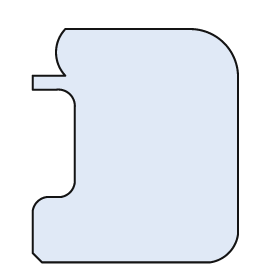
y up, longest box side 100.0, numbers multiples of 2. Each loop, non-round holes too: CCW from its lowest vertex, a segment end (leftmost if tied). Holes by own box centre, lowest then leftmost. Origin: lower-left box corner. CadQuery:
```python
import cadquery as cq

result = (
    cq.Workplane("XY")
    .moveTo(4.0, 0.0)
    .lineTo(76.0, 0.0)
    .threePointArc((84.0, 4.0), (88.0, 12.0))
    .lineTo(88.0, 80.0)
    .threePointArc((82.0, 94.0), (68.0, 100.0))
    .lineTo(14.0, 100.0)
    .threePointArc((10.0, 90.0), (14.0, 80.0))
    .lineTo(0.0, 80.0)
    .lineTo(0.0, 74.0)
    .lineTo(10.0, 74.0)
    .threePointArc((16.0, 72.0), (18.0, 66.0))
    .lineTo(18.0, 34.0)
    .threePointArc((16.0, 30.0), (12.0, 28.0))
    .lineTo(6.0, 28.0)
    .threePointArc((2.0, 26.0), (0.0, 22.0))
    .lineTo(0.0, 4.0)
    .close()
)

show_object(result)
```